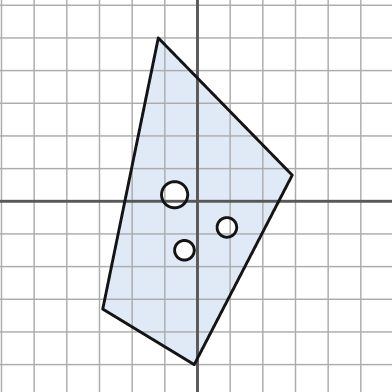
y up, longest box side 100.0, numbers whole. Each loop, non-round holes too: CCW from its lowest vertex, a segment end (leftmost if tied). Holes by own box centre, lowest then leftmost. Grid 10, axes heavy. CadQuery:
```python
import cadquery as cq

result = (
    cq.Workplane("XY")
    .moveTo(-1.0, -50.0)
    .lineTo(29.0, 8.0)
    .lineTo(-12.0, 50.0)
    .lineTo(-29.0, -33.0)
    .close()
    .moveTo(-4.0, -15.0)
    .circle(3.0)
    .moveTo(9.0, -8.0)
    .circle(3.0)
    .moveTo(-7.0, 2.0)
    .circle(4.0)
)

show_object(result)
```